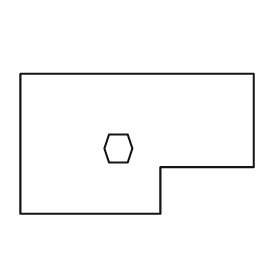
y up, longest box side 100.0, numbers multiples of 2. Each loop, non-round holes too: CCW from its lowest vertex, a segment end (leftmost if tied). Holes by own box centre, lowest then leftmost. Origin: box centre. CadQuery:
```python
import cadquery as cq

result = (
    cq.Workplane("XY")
    .moveTo(-50.0, -30.0)
    .lineTo(10.0, -30.0)
    .lineTo(10.0, -10.0)
    .lineTo(50.0, -10.0)
    .lineTo(50.0, 30.0)
    .lineTo(-50.0, 30.0)
    .close()
    .moveTo(-12.0, -8.0)
    .lineTo(-4.0, -8.0)
    .lineTo(-2.0, -2.0)
    .lineTo(-4.0, 4.0)
    .lineTo(-12.0, 4.0)
    .lineTo(-14.0, -2.0)
    .close()
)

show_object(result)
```